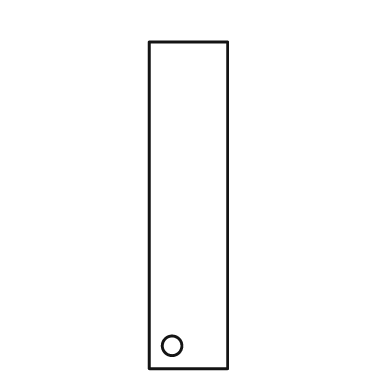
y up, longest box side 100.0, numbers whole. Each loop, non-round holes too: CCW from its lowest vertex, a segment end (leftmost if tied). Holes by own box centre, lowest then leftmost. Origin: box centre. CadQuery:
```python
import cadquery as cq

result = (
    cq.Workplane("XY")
    .moveTo(-12.0, -50.0)
    .lineTo(12.0, -50.0)
    .lineTo(12.0, 50.0)
    .lineTo(-12.0, 50.0)
    .close()
    .moveTo(-5.0, -43.0)
    .circle(3.0)
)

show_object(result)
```